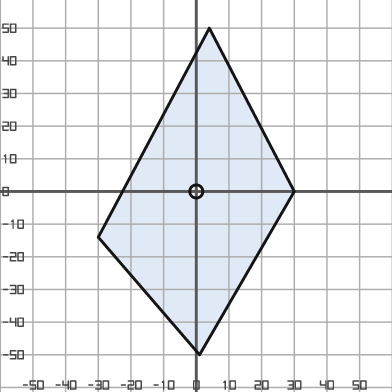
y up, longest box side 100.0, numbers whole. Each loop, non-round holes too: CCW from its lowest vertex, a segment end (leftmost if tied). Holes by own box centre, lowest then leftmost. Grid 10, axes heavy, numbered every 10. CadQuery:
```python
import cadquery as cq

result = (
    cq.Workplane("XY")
    .moveTo(1.0, -50.0)
    .lineTo(30.0, 0.0)
    .lineTo(4.0, 50.0)
    .lineTo(-30.0, -14.0)
    .close()
    .moveTo(0.0, 0.0)
    .circle(2.0)
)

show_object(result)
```